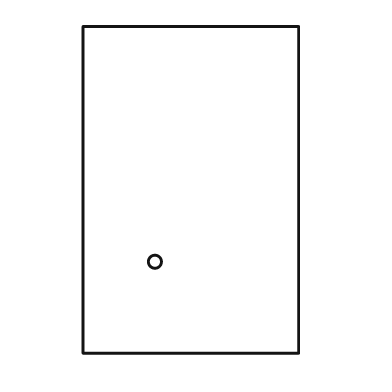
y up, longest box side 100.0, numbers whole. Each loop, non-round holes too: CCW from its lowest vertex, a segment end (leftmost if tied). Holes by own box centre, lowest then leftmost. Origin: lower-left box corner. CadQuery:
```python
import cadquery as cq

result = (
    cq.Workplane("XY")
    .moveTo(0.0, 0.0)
    .lineTo(66.0, 0.0)
    .lineTo(66.0, 100.0)
    .lineTo(0.0, 100.0)
    .close()
    .moveTo(22.0, 28.0)
    .circle(2.0)
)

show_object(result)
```